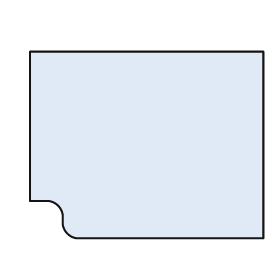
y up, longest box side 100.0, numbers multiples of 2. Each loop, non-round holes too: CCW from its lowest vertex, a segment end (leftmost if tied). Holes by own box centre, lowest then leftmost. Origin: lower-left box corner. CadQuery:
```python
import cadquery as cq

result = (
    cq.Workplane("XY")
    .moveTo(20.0, 0.0)
    .lineTo(100.0, 0.0)
    .lineTo(100.0, 80.0)
    .lineTo(0.0, 80.0)
    .lineTo(0.0, 16.0)
    .lineTo(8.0, 16.0)
    .threePointArc((12.0, 14.0), (14.0, 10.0))
    .lineTo(14.0, 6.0)
    .threePointArc((16.0, 2.0), (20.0, 0.0))
    .close()
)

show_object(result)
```